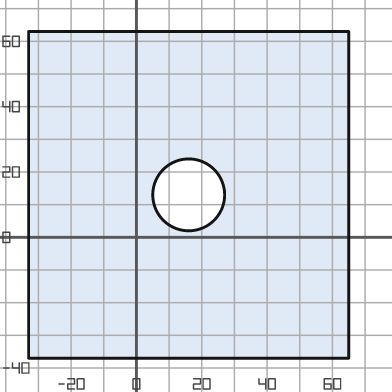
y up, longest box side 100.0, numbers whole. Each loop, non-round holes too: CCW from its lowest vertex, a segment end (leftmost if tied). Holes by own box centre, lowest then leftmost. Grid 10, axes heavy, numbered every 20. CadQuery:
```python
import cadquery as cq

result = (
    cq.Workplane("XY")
    .moveTo(-33.0, -37.0)
    .lineTo(65.0, -37.0)
    .lineTo(65.0, 63.0)
    .lineTo(-33.0, 63.0)
    .close()
    .moveTo(16.0, 13.0)
    .circle(11.0)
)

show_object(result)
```